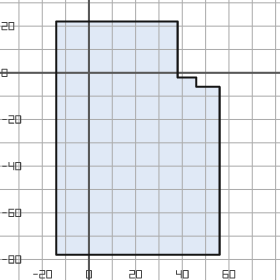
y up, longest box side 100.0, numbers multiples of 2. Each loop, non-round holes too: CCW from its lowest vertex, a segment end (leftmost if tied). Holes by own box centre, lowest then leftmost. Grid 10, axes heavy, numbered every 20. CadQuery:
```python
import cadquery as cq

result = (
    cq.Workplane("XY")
    .moveTo(-14.0, -78.0)
    .lineTo(56.0, -78.0)
    .lineTo(56.0, -6.0)
    .lineTo(46.0, -6.0)
    .lineTo(46.0, -2.0)
    .lineTo(38.0, -2.0)
    .lineTo(38.0, 22.0)
    .lineTo(-14.0, 22.0)
    .close()
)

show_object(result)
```